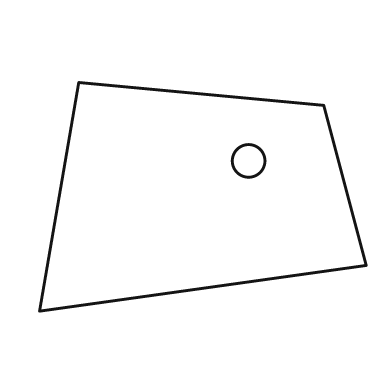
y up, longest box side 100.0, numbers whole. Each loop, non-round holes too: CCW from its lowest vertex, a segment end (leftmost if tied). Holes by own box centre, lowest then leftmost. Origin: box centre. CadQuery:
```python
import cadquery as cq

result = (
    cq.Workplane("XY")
    .moveTo(-50.0, -35.0)
    .lineTo(50.0, -21.0)
    .lineTo(37.0, 28.0)
    .lineTo(-38.0, 35.0)
    .close()
    .moveTo(14.0, 11.0)
    .circle(5.0)
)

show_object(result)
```